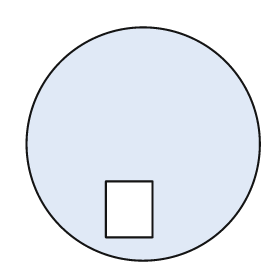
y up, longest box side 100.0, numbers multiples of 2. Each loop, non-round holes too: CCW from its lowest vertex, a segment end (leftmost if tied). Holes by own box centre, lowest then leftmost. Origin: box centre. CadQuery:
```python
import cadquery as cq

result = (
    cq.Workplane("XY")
    .moveTo(0.0, 0.0)
    .circle(50.0)
    .moveTo(-16.0, -40.0)
    .lineTo(4.0, -40.0)
    .lineTo(4.0, -16.0)
    .lineTo(-16.0, -16.0)
    .close()
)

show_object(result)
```